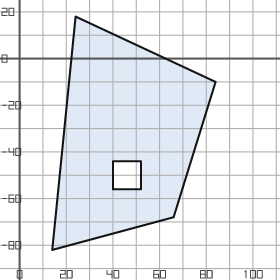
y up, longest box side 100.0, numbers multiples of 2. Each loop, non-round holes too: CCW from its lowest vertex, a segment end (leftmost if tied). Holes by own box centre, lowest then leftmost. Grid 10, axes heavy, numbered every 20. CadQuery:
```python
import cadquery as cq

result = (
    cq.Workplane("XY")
    .moveTo(14.0, -82.0)
    .lineTo(66.0, -68.0)
    .lineTo(84.0, -10.0)
    .lineTo(24.0, 18.0)
    .close()
    .moveTo(40.0, -56.0)
    .lineTo(52.0, -56.0)
    .lineTo(52.0, -44.0)
    .lineTo(40.0, -44.0)
    .close()
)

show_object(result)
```